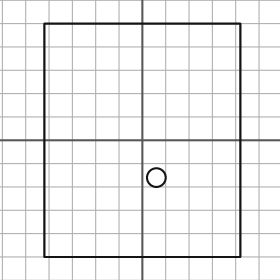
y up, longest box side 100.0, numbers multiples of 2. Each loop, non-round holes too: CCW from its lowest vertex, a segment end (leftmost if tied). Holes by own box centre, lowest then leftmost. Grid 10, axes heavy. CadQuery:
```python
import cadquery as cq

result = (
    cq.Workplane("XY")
    .moveTo(-42.0, -50.0)
    .lineTo(42.0, -50.0)
    .lineTo(42.0, 50.0)
    .lineTo(-42.0, 50.0)
    .close()
    .moveTo(6.0, -16.0)
    .circle(4.0)
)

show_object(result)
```